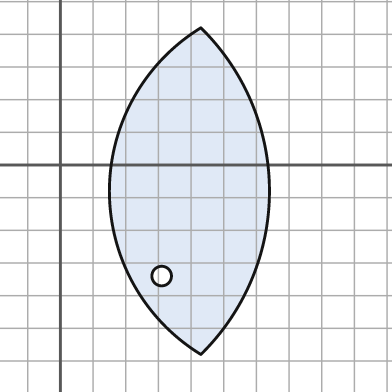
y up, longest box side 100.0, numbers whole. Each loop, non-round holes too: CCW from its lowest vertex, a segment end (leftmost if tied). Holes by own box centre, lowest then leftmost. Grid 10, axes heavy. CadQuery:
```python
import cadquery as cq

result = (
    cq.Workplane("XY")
    .moveTo(43.0, -58.0)
    .threePointArc((64.0, -8.0), (43.0, 42.0))
    .threePointArc((15.0, -8.0), (43.0, -58.0))
    .close()
    .moveTo(31.0, -34.0)
    .circle(3.0)
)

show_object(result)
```